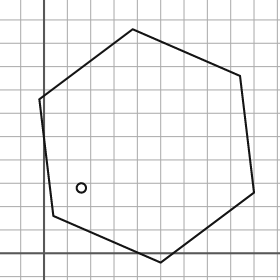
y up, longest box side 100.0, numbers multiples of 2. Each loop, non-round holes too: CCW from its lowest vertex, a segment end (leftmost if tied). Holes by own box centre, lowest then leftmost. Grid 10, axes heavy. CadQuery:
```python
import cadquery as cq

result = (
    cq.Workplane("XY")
    .moveTo(50.0, -4.0)
    .lineTo(90.0, 26.0)
    .lineTo(84.0, 76.0)
    .lineTo(38.0, 96.0)
    .lineTo(-2.0, 66.0)
    .lineTo(4.0, 16.0)
    .close()
    .moveTo(16.0, 28.0)
    .circle(2.0)
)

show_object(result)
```